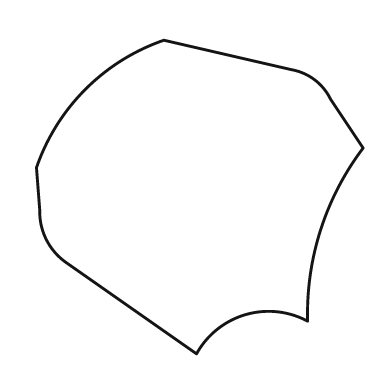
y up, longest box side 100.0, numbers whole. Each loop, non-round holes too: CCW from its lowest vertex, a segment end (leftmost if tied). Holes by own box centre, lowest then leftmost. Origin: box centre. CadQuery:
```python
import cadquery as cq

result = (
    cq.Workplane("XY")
    .moveTo(-1.0, -48.0)
    .threePointArc((14.0, -36.0), (33.0, -38.0))
    .threePointArc((37.0, -10.0), (50.0, 15.0))
    .lineTo(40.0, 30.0)
    .threePointArc((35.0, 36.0), (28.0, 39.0))
    .lineTo(-11.0, 48.0)
    .threePointArc((-35.0, 33.0), (-50.0, 9.0))
    .lineTo(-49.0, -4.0)
    .threePointArc((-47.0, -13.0), (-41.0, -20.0))
    .close()
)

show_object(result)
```